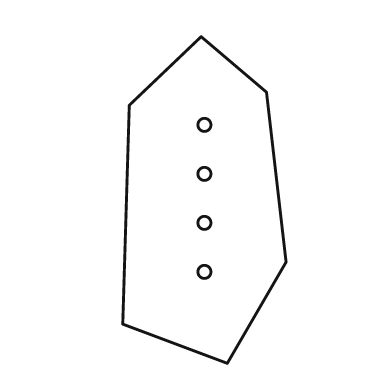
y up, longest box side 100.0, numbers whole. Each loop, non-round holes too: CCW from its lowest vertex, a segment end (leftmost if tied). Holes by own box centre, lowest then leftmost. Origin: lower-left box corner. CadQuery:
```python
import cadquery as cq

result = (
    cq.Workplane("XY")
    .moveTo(32.0, 0.0)
    .lineTo(50.0, 31.0)
    .lineTo(44.0, 83.0)
    .lineTo(24.0, 100.0)
    .lineTo(2.0, 79.0)
    .lineTo(0.0, 12.0)
    .close()
    .moveTo(25.0, 28.0)
    .circle(2.0)
    .moveTo(25.0, 43.0)
    .circle(2.0)
    .moveTo(25.0, 58.0)
    .circle(2.0)
    .moveTo(25.0, 73.0)
    .circle(2.0)
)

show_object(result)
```